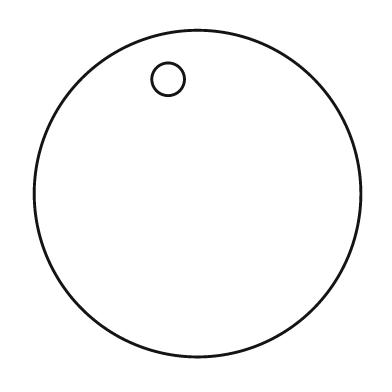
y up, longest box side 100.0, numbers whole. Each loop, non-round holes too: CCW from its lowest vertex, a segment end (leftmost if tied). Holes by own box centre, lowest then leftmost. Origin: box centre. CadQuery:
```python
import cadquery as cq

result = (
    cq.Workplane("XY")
    .moveTo(0.0, 0.0)
    .circle(50.0)
    .moveTo(-9.0, 35.0)
    .circle(5.0)
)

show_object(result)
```